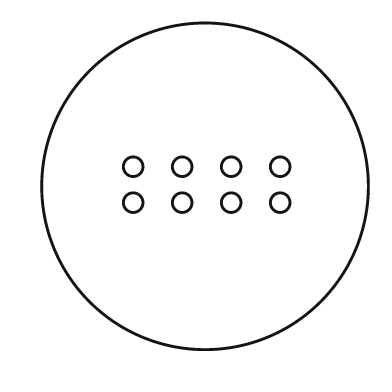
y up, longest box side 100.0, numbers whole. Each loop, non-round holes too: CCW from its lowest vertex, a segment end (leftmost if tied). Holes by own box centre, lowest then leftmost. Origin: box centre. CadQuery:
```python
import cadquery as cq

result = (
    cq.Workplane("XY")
    .moveTo(0.0, 0.0)
    .circle(50.0)
    .moveTo(-22.0, -5.0)
    .circle(3.0)
    .moveTo(-7.0, -5.0)
    .circle(3.0)
    .moveTo(8.0, -5.0)
    .circle(3.0)
    .moveTo(23.0, -5.0)
    .circle(3.0)
    .moveTo(-22.0, 6.0)
    .circle(3.0)
    .moveTo(-7.0, 6.0)
    .circle(3.0)
    .moveTo(8.0, 6.0)
    .circle(3.0)
    .moveTo(23.0, 6.0)
    .circle(3.0)
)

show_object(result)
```